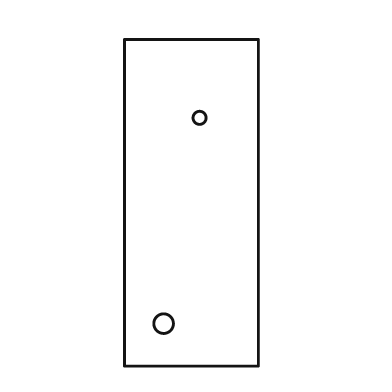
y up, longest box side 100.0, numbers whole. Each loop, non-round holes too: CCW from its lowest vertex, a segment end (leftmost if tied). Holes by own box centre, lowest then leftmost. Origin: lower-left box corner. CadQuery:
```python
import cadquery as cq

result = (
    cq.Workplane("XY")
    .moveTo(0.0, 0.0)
    .lineTo(41.0, 0.0)
    .lineTo(41.0, 100.0)
    .lineTo(0.0, 100.0)
    .close()
    .moveTo(12.0, 13.0)
    .circle(3.0)
    .moveTo(23.0, 76.0)
    .circle(2.0)
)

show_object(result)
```